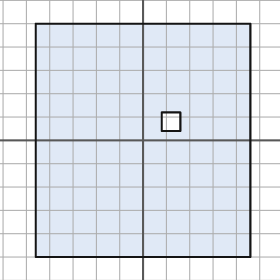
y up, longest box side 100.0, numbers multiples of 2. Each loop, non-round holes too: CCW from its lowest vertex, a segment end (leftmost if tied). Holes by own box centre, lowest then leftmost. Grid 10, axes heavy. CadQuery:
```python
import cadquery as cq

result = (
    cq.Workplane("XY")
    .moveTo(-46.0, -50.0)
    .lineTo(46.0, -50.0)
    .lineTo(46.0, 50.0)
    .lineTo(-46.0, 50.0)
    .close()
    .moveTo(8.0, 4.0)
    .lineTo(16.0, 4.0)
    .lineTo(16.0, 12.0)
    .lineTo(8.0, 12.0)
    .close()
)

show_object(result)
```